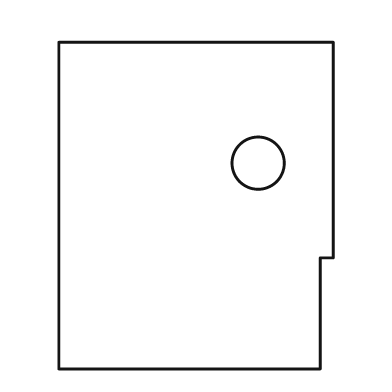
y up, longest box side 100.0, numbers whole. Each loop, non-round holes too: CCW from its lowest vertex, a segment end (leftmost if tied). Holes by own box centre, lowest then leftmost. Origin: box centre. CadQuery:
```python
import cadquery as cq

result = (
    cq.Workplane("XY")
    .moveTo(-42.0, -50.0)
    .lineTo(38.0, -50.0)
    .lineTo(38.0, -16.0)
    .lineTo(42.0, -16.0)
    .lineTo(42.0, 50.0)
    .lineTo(-42.0, 50.0)
    .close()
    .moveTo(19.0, 13.0)
    .circle(8.0)
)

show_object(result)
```